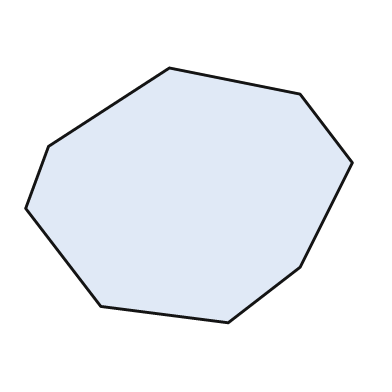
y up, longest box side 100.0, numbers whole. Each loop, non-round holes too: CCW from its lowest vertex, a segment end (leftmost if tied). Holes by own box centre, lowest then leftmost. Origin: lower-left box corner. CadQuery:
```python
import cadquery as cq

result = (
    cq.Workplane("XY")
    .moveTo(62.0, 0.0)
    .lineTo(84.0, 17.0)
    .lineTo(100.0, 49.0)
    .lineTo(84.0, 70.0)
    .lineTo(44.0, 78.0)
    .lineTo(7.0, 54.0)
    .lineTo(0.0, 35.0)
    .lineTo(23.0, 5.0)
    .close()
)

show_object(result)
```